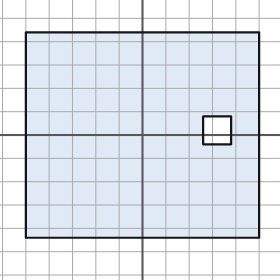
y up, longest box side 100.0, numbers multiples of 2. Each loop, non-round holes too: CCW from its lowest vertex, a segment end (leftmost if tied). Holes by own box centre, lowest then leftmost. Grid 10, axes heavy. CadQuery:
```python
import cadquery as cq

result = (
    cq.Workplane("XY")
    .moveTo(-50.0, -44.0)
    .lineTo(50.0, -44.0)
    .lineTo(50.0, 44.0)
    .lineTo(-50.0, 44.0)
    .close()
    .moveTo(26.0, -4.0)
    .lineTo(38.0, -4.0)
    .lineTo(38.0, 8.0)
    .lineTo(26.0, 8.0)
    .close()
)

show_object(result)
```